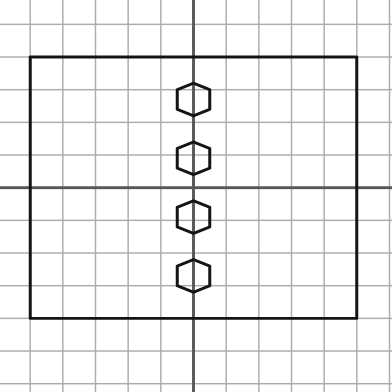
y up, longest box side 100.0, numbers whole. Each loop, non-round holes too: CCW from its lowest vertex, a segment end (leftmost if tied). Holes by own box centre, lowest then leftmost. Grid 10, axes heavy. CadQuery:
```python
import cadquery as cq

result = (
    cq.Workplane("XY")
    .moveTo(-50.0, -40.0)
    .lineTo(50.0, -40.0)
    .lineTo(50.0, 40.0)
    .lineTo(-50.0, 40.0)
    .close()
    .moveTo(0.0, -32.0)
    .lineTo(5.0, -30.0)
    .lineTo(5.0, -24.0)
    .lineTo(0.0, -22.0)
    .lineTo(-5.0, -24.0)
    .lineTo(-5.0, -30.0)
    .close()
    .moveTo(0.0, -14.0)
    .lineTo(5.0, -12.0)
    .lineTo(5.0, -6.0)
    .lineTo(0.0, -4.0)
    .lineTo(-5.0, -6.0)
    .lineTo(-5.0, -12.0)
    .close()
    .moveTo(0.0, 4.0)
    .lineTo(5.0, 6.0)
    .lineTo(5.0, 12.0)
    .lineTo(0.0, 14.0)
    .lineTo(-5.0, 12.0)
    .lineTo(-5.0, 6.0)
    .close()
    .moveTo(0.0, 22.0)
    .lineTo(5.0, 24.0)
    .lineTo(5.0, 30.0)
    .lineTo(0.0, 32.0)
    .lineTo(-5.0, 30.0)
    .lineTo(-5.0, 24.0)
    .close()
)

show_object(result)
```